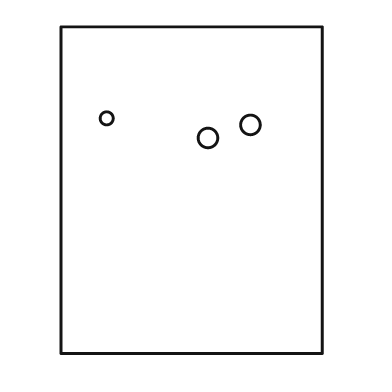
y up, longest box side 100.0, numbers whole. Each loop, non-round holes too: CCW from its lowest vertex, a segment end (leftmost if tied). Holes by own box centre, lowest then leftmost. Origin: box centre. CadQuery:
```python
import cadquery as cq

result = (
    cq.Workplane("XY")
    .moveTo(-40.0, -50.0)
    .lineTo(40.0, -50.0)
    .lineTo(40.0, 50.0)
    .lineTo(-40.0, 50.0)
    .close()
    .moveTo(5.0, 16.0)
    .circle(3.0)
    .moveTo(18.0, 20.0)
    .circle(3.0)
    .moveTo(-26.0, 22.0)
    .circle(2.0)
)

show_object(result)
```